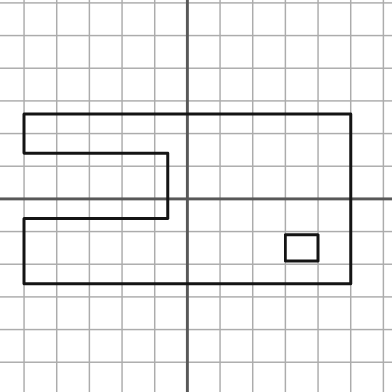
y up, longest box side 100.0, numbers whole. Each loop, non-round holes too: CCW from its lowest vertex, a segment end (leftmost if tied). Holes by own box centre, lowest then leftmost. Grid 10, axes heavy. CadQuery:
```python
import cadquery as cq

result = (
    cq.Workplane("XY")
    .moveTo(-50.0, -26.0)
    .lineTo(50.0, -26.0)
    .lineTo(50.0, 26.0)
    .lineTo(-50.0, 26.0)
    .lineTo(-50.0, 14.0)
    .lineTo(-6.0, 14.0)
    .lineTo(-6.0, -6.0)
    .lineTo(-50.0, -6.0)
    .close()
    .moveTo(30.0, -19.0)
    .lineTo(40.0, -19.0)
    .lineTo(40.0, -11.0)
    .lineTo(30.0, -11.0)
    .close()
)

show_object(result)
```